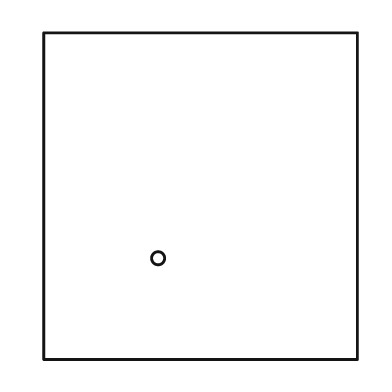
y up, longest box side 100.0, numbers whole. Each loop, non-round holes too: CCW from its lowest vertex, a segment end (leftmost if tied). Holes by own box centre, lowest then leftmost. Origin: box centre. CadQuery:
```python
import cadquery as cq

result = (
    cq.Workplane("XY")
    .moveTo(-48.0, -50.0)
    .lineTo(48.0, -50.0)
    .lineTo(48.0, 50.0)
    .lineTo(-48.0, 50.0)
    .close()
    .moveTo(-13.0, -19.0)
    .circle(2.0)
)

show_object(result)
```